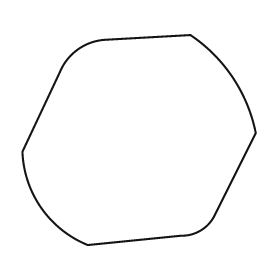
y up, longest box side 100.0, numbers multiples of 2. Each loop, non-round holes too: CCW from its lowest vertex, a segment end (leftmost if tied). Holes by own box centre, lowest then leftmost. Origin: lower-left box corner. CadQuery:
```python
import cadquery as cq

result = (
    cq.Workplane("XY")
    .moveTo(28.0, 0.0)
    .lineTo(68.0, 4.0)
    .threePointArc((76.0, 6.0), (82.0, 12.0))
    .lineTo(100.0, 48.0)
    .threePointArc((90.0, 72.0), (72.0, 90.0))
    .lineTo(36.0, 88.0)
    .threePointArc((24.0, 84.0), (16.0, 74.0))
    .lineTo(0.0, 40.0)
    .threePointArc((8.0, 16.0), (28.0, 0.0))
    .close()
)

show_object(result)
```